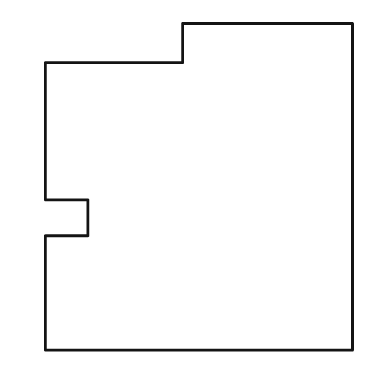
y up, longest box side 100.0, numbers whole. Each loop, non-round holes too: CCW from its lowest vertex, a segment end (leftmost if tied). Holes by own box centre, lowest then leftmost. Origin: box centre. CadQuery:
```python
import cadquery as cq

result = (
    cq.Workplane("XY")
    .moveTo(-47.0, -50.0)
    .lineTo(47.0, -50.0)
    .lineTo(47.0, 50.0)
    .lineTo(-5.0, 50.0)
    .lineTo(-5.0, 38.0)
    .lineTo(-47.0, 38.0)
    .lineTo(-47.0, -4.0)
    .lineTo(-34.0, -4.0)
    .lineTo(-34.0, -15.0)
    .lineTo(-47.0, -15.0)
    .close()
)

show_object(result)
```